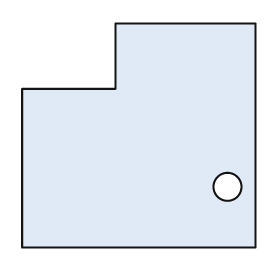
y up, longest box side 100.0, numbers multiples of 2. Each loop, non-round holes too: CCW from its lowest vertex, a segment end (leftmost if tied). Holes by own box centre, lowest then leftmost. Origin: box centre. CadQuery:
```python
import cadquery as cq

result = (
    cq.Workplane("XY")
    .moveTo(-50.0, -48.0)
    .lineTo(50.0, -48.0)
    .lineTo(50.0, 48.0)
    .lineTo(-10.0, 48.0)
    .lineTo(-10.0, 20.0)
    .lineTo(-50.0, 20.0)
    .close()
    .moveTo(38.0, -22.0)
    .circle(6.0)
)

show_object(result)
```